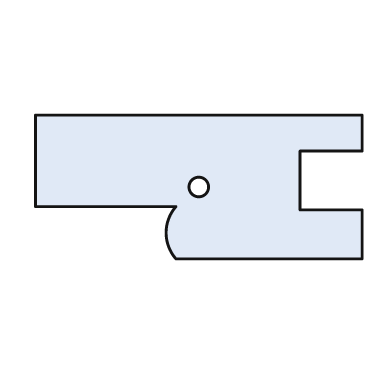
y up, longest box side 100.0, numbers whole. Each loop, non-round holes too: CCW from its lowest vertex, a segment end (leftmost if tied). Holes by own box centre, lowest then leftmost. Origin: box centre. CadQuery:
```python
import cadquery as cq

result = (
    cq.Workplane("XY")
    .moveTo(-7.0, -22.0)
    .lineTo(50.0, -22.0)
    .lineTo(50.0, -7.0)
    .lineTo(31.0, -7.0)
    .lineTo(31.0, 11.0)
    .lineTo(50.0, 11.0)
    .lineTo(50.0, 22.0)
    .lineTo(-50.0, 22.0)
    .lineTo(-50.0, -6.0)
    .lineTo(-7.0, -6.0)
    .threePointArc((-10.0, -14.0), (-7.0, -22.0))
    .close()
    .moveTo(0.0, 0.0)
    .circle(3.0)
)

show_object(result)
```